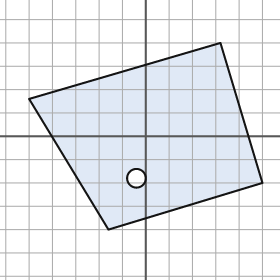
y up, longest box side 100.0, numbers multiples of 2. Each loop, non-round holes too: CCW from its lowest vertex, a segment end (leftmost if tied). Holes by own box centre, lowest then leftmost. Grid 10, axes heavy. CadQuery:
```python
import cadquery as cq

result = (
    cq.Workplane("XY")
    .moveTo(-16.0, -40.0)
    .lineTo(50.0, -20.0)
    .lineTo(32.0, 40.0)
    .lineTo(-50.0, 16.0)
    .close()
    .moveTo(-4.0, -18.0)
    .circle(4.0)
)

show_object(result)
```